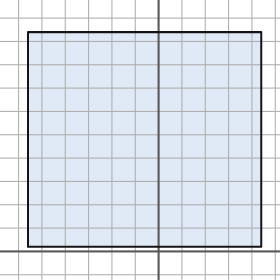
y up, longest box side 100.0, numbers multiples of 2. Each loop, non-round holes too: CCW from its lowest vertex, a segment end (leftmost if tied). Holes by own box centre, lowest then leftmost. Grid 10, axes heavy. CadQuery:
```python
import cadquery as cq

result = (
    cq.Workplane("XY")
    .moveTo(-56.0, 2.0)
    .lineTo(44.0, 2.0)
    .lineTo(44.0, 94.0)
    .lineTo(-56.0, 94.0)
    .close()
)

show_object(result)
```